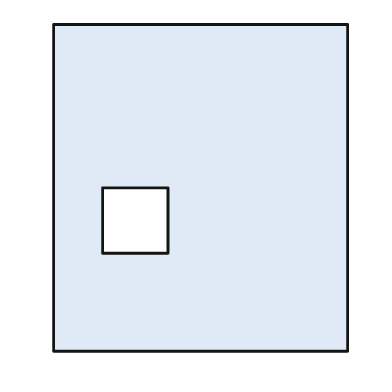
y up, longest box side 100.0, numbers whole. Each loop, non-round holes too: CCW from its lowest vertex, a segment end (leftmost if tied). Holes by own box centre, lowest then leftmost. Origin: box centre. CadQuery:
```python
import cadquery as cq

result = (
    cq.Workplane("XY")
    .moveTo(-45.0, -50.0)
    .lineTo(45.0, -50.0)
    .lineTo(45.0, 50.0)
    .lineTo(-45.0, 50.0)
    .close()
    .moveTo(-30.0, -20.0)
    .lineTo(-10.0, -20.0)
    .lineTo(-10.0, 0.0)
    .lineTo(-30.0, 0.0)
    .close()
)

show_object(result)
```